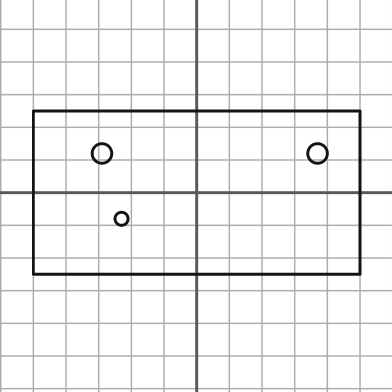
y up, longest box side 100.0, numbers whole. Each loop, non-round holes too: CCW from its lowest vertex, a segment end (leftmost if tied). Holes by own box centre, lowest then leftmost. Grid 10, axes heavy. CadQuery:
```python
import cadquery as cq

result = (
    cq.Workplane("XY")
    .moveTo(-50.0, -25.0)
    .lineTo(50.0, -25.0)
    .lineTo(50.0, 25.0)
    .lineTo(-50.0, 25.0)
    .close()
    .moveTo(-23.0, -8.0)
    .circle(2.0)
    .moveTo(-29.0, 12.0)
    .circle(3.0)
    .moveTo(37.0, 12.0)
    .circle(3.0)
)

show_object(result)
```